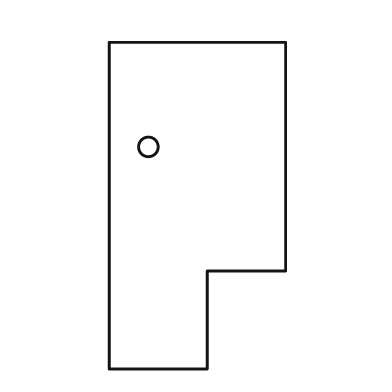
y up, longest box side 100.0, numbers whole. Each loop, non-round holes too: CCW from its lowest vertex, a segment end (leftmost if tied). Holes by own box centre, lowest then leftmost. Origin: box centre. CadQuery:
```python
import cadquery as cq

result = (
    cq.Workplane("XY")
    .moveTo(-27.0, -50.0)
    .lineTo(3.0, -50.0)
    .lineTo(3.0, -20.0)
    .lineTo(27.0, -20.0)
    .lineTo(27.0, 50.0)
    .lineTo(-27.0, 50.0)
    .close()
    .moveTo(-15.0, 18.0)
    .circle(3.0)
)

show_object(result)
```